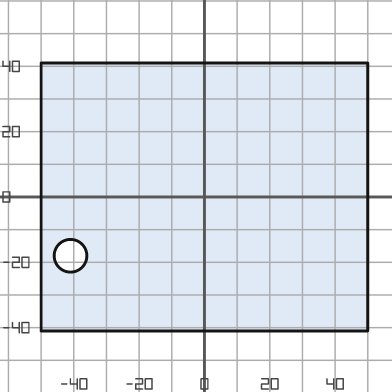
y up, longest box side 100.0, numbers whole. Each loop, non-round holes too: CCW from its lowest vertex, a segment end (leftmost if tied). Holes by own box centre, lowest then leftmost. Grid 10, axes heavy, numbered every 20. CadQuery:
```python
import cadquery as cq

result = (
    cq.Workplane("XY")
    .moveTo(-50.0, -41.0)
    .lineTo(50.0, -41.0)
    .lineTo(50.0, 41.0)
    .lineTo(-50.0, 41.0)
    .close()
    .moveTo(-41.0, -18.0)
    .circle(5.0)
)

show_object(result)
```